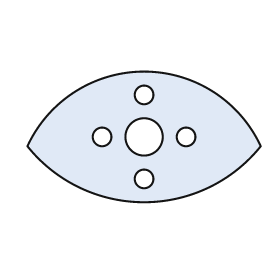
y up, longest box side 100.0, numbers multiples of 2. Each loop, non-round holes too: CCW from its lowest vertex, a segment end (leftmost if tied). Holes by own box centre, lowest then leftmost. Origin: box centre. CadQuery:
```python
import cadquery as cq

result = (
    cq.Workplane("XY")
    .moveTo(-50.0, -4.0)
    .threePointArc((0.0, -28.0), (50.0, -4.0))
    .threePointArc((0.0, 28.0), (-50.0, -4.0))
    .close()
    .moveTo(0.0, -18.0)
    .circle(4.0)
    .moveTo(-18.0, 0.0)
    .circle(4.0)
    .moveTo(0.0, 0.0)
    .circle(8.0)
    .moveTo(18.0, 0.0)
    .circle(4.0)
    .moveTo(0.0, 18.0)
    .circle(4.0)
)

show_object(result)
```